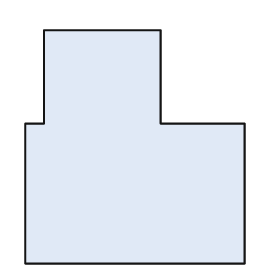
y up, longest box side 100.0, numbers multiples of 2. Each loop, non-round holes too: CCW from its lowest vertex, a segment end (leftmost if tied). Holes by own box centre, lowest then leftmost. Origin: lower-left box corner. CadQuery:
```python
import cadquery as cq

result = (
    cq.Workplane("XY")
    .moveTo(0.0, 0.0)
    .lineTo(94.0, 0.0)
    .lineTo(94.0, 60.0)
    .lineTo(58.0, 60.0)
    .lineTo(58.0, 100.0)
    .lineTo(8.0, 100.0)
    .lineTo(8.0, 60.0)
    .lineTo(0.0, 60.0)
    .close()
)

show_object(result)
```